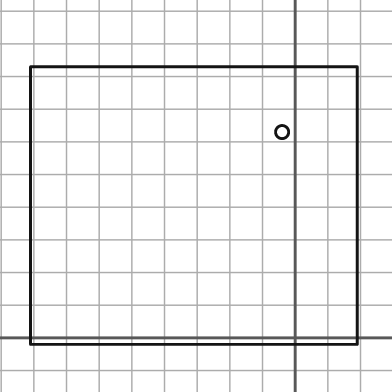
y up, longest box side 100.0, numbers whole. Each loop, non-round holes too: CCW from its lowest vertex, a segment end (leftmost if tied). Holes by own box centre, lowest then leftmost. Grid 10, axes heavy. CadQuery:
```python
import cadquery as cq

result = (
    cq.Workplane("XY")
    .moveTo(-81.0, -2.0)
    .lineTo(19.0, -2.0)
    .lineTo(19.0, 83.0)
    .lineTo(-81.0, 83.0)
    .close()
    .moveTo(-4.0, 63.0)
    .circle(2.0)
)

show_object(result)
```